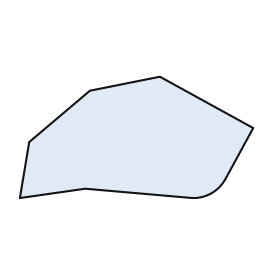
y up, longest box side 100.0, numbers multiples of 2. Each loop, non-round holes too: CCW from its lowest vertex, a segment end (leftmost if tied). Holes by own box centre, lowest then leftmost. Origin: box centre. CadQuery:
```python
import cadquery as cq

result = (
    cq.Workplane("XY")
    .moveTo(-50.0, -26.0)
    .lineTo(-22.0, -22.0)
    .lineTo(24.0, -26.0)
    .threePointArc((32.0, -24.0), (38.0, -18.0))
    .lineTo(50.0, 4.0)
    .lineTo(10.0, 26.0)
    .lineTo(-20.0, 20.0)
    .lineTo(-46.0, -2.0)
    .close()
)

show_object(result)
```